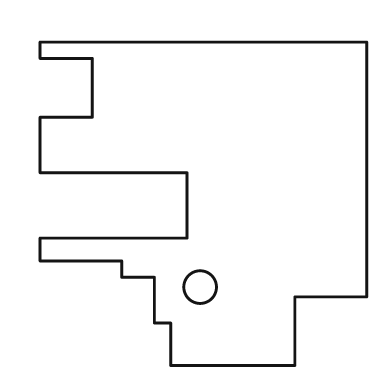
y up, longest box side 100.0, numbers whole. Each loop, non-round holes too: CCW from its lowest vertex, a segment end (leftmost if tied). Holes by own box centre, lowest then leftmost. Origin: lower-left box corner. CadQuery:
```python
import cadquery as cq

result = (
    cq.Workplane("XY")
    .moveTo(40.0, 0.0)
    .lineTo(78.0, 0.0)
    .lineTo(78.0, 21.0)
    .lineTo(100.0, 21.0)
    .lineTo(100.0, 99.0)
    .lineTo(0.0, 99.0)
    .lineTo(0.0, 94.0)
    .lineTo(16.0, 94.0)
    .lineTo(16.0, 76.0)
    .lineTo(0.0, 76.0)
    .lineTo(0.0, 59.0)
    .lineTo(45.0, 59.0)
    .lineTo(45.0, 39.0)
    .lineTo(0.0, 39.0)
    .lineTo(0.0, 32.0)
    .lineTo(25.0, 32.0)
    .lineTo(25.0, 27.0)
    .lineTo(35.0, 27.0)
    .lineTo(35.0, 13.0)
    .lineTo(40.0, 13.0)
    .close()
    .moveTo(49.0, 24.0)
    .circle(5.0)
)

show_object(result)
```